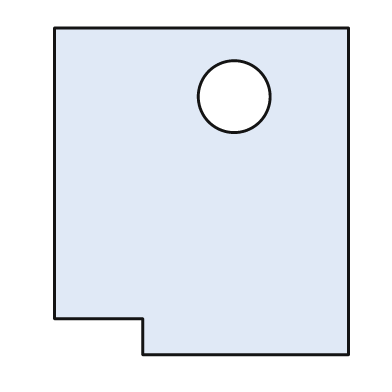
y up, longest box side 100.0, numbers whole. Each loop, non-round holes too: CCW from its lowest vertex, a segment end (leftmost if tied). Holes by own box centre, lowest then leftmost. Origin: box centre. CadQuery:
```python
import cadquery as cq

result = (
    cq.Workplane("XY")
    .moveTo(-18.0, -50.0)
    .lineTo(45.0, -50.0)
    .lineTo(45.0, 50.0)
    .lineTo(-45.0, 50.0)
    .lineTo(-45.0, -39.0)
    .lineTo(-18.0, -39.0)
    .close()
    .moveTo(10.0, 29.0)
    .circle(11.0)
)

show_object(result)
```